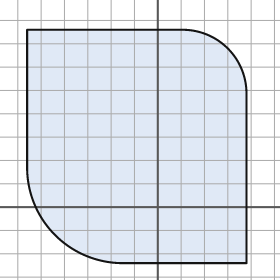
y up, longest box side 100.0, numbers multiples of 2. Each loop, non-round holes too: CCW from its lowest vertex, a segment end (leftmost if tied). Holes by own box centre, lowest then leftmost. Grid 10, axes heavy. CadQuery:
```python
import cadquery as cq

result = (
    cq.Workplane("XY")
    .moveTo(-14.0, -24.0)
    .lineTo(38.0, -24.0)
    .lineTo(38.0, 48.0)
    .threePointArc((30.0, 68.0), (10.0, 76.0))
    .lineTo(-56.0, 76.0)
    .lineTo(-56.0, 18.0)
    .threePointArc((-44.0, -12.0), (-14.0, -24.0))
    .close()
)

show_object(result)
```